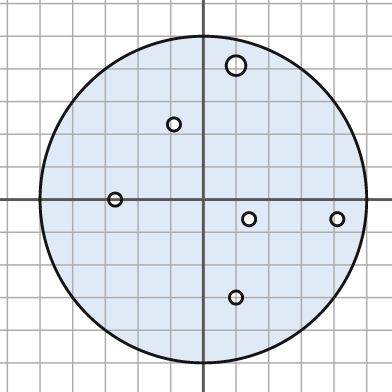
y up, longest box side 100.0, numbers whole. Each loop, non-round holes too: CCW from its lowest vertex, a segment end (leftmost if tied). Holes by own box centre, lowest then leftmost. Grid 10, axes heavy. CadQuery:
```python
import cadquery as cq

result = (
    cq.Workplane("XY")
    .moveTo(0.0, 0.0)
    .circle(50.0)
    .moveTo(10.0, -30.0)
    .circle(2.0)
    .moveTo(14.0, -6.0)
    .circle(2.0)
    .moveTo(41.0, -6.0)
    .circle(2.0)
    .moveTo(-27.0, 0.0)
    .circle(2.0)
    .moveTo(-9.0, 23.0)
    .circle(2.0)
    .moveTo(10.0, 41.0)
    .circle(3.0)
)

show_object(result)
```